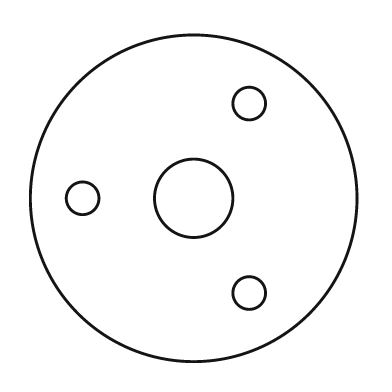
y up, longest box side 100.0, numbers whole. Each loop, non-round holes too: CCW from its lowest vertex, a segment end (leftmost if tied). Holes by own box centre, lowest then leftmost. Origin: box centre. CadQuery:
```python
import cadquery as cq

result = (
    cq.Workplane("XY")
    .moveTo(0.0, 0.0)
    .circle(50.0)
    .moveTo(17.0, -29.0)
    .circle(5.0)
    .moveTo(-34.0, 0.0)
    .circle(5.0)
    .moveTo(0.0, 0.0)
    .circle(12.0)
    .moveTo(17.0, 29.0)
    .circle(5.0)
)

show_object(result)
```